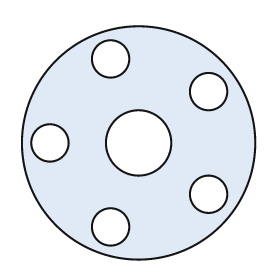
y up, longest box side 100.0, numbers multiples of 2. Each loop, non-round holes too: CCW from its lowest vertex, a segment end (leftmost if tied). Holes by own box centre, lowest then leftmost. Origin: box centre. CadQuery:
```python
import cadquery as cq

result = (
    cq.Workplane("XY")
    .moveTo(0.0, 0.0)
    .circle(50.0)
    .moveTo(-12.0, -36.0)
    .circle(8.0)
    .moveTo(30.0, -22.0)
    .circle(8.0)
    .moveTo(-38.0, 0.0)
    .circle(8.0)
    .moveTo(0.0, 0.0)
    .circle(14.0)
    .moveTo(30.0, 22.0)
    .circle(8.0)
    .moveTo(-12.0, 36.0)
    .circle(8.0)
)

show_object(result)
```